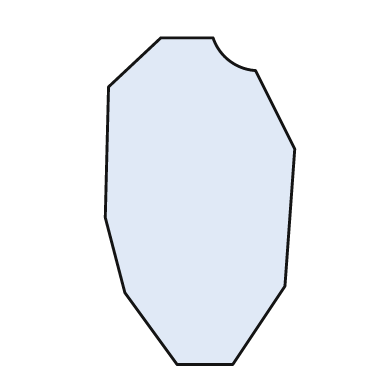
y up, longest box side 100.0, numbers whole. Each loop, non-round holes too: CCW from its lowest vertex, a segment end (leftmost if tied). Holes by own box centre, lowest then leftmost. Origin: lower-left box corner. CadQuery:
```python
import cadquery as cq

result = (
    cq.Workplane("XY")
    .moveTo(22.0, 0.0)
    .lineTo(39.0, 0.0)
    .lineTo(55.0, 24.0)
    .lineTo(58.0, 66.0)
    .lineTo(46.0, 90.0)
    .threePointArc((38.0, 93.0), (33.0, 100.0))
    .lineTo(17.0, 100.0)
    .lineTo(1.0, 85.0)
    .lineTo(0.0, 45.0)
    .lineTo(6.0, 22.0)
    .close()
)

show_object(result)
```